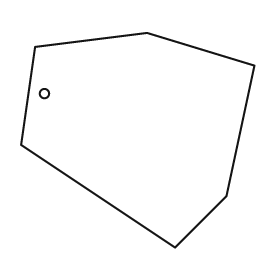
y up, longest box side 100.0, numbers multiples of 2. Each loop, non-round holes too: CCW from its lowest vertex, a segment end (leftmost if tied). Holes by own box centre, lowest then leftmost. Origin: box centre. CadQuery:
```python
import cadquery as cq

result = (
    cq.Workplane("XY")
    .moveTo(16.0, -46.0)
    .lineTo(38.0, -24.0)
    .lineTo(50.0, 32.0)
    .lineTo(4.0, 46.0)
    .lineTo(-44.0, 40.0)
    .lineTo(-50.0, -2.0)
    .close()
    .moveTo(-40.0, 20.0)
    .circle(2.0)
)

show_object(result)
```